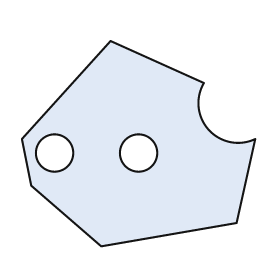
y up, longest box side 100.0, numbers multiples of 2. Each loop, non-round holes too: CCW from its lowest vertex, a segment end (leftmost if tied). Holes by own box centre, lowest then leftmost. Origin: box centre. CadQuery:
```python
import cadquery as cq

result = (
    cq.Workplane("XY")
    .moveTo(-16.0, -44.0)
    .lineTo(42.0, -34.0)
    .lineTo(50.0, 2.0)
    .threePointArc((30.0, 6.0), (28.0, 26.0))
    .lineTo(-12.0, 44.0)
    .lineTo(-50.0, 2.0)
    .lineTo(-46.0, -18.0)
    .close()
    .moveTo(-36.0, -4.0)
    .circle(8.0)
    .moveTo(0.0, -4.0)
    .circle(8.0)
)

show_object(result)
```